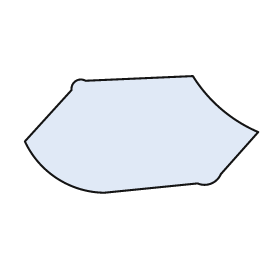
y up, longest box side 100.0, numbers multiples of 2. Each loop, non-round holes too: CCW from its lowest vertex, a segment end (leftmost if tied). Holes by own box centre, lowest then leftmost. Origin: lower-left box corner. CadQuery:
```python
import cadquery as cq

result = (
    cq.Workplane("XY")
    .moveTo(34.0, 0.0)
    .lineTo(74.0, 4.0)
    .threePointArc((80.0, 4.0), (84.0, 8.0))
    .lineTo(100.0, 26.0)
    .threePointArc((84.0, 36.0), (72.0, 50.0))
    .lineTo(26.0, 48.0)
    .threePointArc((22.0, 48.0), (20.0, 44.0))
    .lineTo(0.0, 22.0)
    .threePointArc((14.0, 6.0), (34.0, 0.0))
    .close()
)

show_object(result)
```